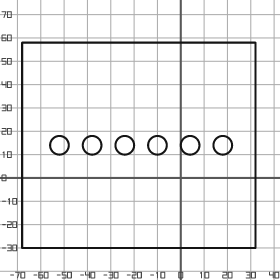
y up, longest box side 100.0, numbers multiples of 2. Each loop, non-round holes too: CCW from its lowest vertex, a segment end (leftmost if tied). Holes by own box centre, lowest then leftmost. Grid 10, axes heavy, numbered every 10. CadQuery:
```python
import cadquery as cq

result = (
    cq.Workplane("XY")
    .moveTo(-68.0, -30.0)
    .lineTo(32.0, -30.0)
    .lineTo(32.0, 58.0)
    .lineTo(-68.0, 58.0)
    .close()
    .moveTo(-52.0, 14.0)
    .circle(4.0)
    .moveTo(-38.0, 14.0)
    .circle(4.0)
    .moveTo(-24.0, 14.0)
    .circle(4.0)
    .moveTo(-10.0, 14.0)
    .circle(4.0)
    .moveTo(4.0, 14.0)
    .circle(4.0)
    .moveTo(18.0, 14.0)
    .circle(4.0)
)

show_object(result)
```